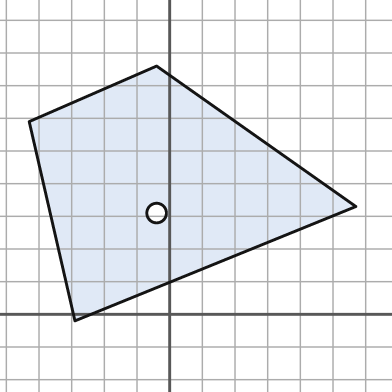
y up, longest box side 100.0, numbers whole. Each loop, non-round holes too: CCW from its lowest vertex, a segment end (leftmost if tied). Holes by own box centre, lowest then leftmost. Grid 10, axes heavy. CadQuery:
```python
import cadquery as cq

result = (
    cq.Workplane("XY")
    .moveTo(-29.0, -2.0)
    .lineTo(57.0, 33.0)
    .lineTo(-4.0, 76.0)
    .lineTo(-43.0, 59.0)
    .close()
    .moveTo(-4.0, 31.0)
    .circle(3.0)
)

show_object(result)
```